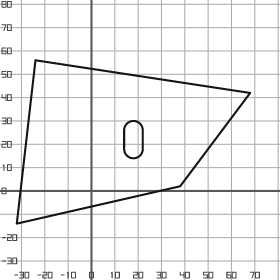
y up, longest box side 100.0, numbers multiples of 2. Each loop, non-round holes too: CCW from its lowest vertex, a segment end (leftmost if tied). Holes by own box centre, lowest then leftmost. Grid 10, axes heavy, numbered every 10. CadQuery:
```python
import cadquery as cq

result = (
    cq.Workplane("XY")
    .moveTo(-32.0, -14.0)
    .lineTo(38.0, 2.0)
    .lineTo(68.0, 42.0)
    .lineTo(-24.0, 56.0)
    .close()
    .moveTo(14.0, 18.0)
    .threePointArc((18.0, 14.0), (22.0, 18.0))
    .lineTo(22.0, 26.0)
    .threePointArc((18.0, 30.0), (14.0, 26.0))
    .close()
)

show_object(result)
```